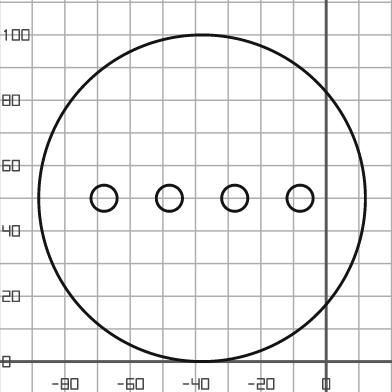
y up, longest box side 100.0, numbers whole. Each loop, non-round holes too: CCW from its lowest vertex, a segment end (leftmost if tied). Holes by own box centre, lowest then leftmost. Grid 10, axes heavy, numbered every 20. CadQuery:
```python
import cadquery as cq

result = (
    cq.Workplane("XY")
    .moveTo(-38.0, 50.0)
    .circle(50.0)
    .moveTo(-68.0, 50.0)
    .circle(4.0)
    .moveTo(-48.0, 50.0)
    .circle(4.0)
    .moveTo(-28.0, 50.0)
    .circle(4.0)
    .moveTo(-8.0, 50.0)
    .circle(4.0)
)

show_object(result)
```